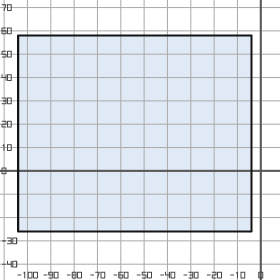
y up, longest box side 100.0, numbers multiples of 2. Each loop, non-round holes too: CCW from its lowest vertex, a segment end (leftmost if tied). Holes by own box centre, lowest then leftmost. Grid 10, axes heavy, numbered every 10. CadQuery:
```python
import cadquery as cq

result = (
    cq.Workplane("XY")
    .moveTo(-104.0, -26.0)
    .lineTo(-4.0, -26.0)
    .lineTo(-4.0, 58.0)
    .lineTo(-104.0, 58.0)
    .close()
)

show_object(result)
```